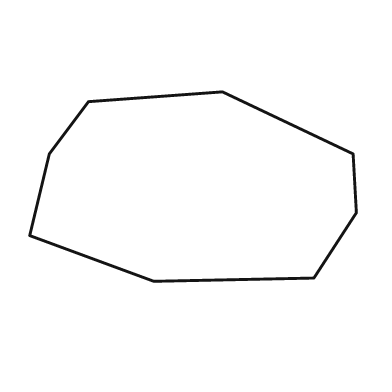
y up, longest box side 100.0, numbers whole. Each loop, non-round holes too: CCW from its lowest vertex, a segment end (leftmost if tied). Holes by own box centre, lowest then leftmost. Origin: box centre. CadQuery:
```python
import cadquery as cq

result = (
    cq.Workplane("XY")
    .moveTo(-12.0, -29.0)
    .lineTo(37.0, -28.0)
    .lineTo(50.0, -8.0)
    .lineTo(49.0, 10.0)
    .lineTo(9.0, 29.0)
    .lineTo(-32.0, 26.0)
    .lineTo(-44.0, 10.0)
    .lineTo(-50.0, -15.0)
    .close()
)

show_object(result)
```